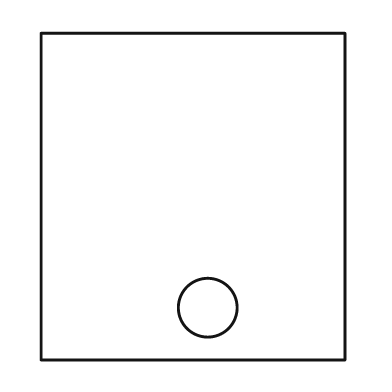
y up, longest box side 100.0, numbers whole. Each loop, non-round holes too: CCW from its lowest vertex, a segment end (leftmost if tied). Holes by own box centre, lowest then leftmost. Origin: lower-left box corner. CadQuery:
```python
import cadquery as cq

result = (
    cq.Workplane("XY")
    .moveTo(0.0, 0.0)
    .lineTo(93.0, 0.0)
    .lineTo(93.0, 100.0)
    .lineTo(0.0, 100.0)
    .close()
    .moveTo(51.0, 16.0)
    .circle(9.0)
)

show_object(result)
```